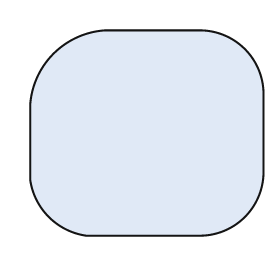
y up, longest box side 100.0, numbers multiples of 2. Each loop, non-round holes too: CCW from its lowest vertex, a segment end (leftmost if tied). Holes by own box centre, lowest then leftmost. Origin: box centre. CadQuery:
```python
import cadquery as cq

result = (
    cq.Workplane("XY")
    .moveTo(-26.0, -44.0)
    .lineTo(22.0, -44.0)
    .threePointArc((42.0, -36.0), (50.0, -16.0))
    .lineTo(50.0, 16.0)
    .threePointArc((42.0, 36.0), (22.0, 44.0))
    .lineTo(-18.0, 44.0)
    .threePointArc((-40.0, 34.0), (-50.0, 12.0))
    .lineTo(-50.0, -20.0)
    .threePointArc((-42.0, -36.0), (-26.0, -44.0))
    .close()
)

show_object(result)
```